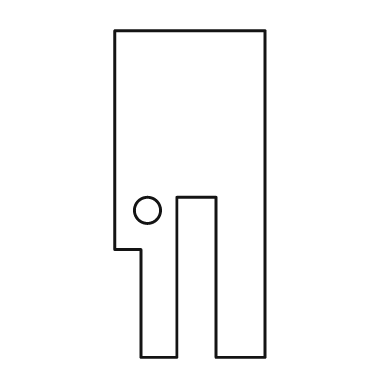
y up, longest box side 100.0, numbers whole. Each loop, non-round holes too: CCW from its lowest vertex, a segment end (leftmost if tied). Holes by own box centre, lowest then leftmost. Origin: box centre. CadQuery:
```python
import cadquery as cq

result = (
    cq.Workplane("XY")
    .moveTo(-15.0, -50.0)
    .lineTo(-4.0, -50.0)
    .lineTo(-4.0, -1.0)
    .lineTo(8.0, -1.0)
    .lineTo(8.0, -50.0)
    .lineTo(23.0, -50.0)
    .lineTo(23.0, 50.0)
    .lineTo(-23.0, 50.0)
    .lineTo(-23.0, -17.0)
    .lineTo(-15.0, -17.0)
    .close()
    .moveTo(-13.0, -5.0)
    .circle(4.0)
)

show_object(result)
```